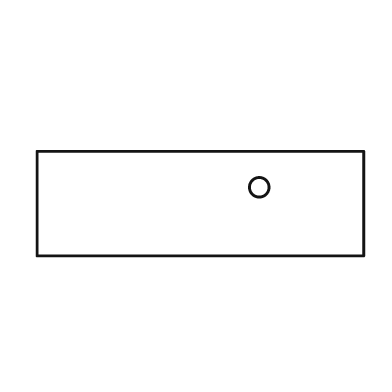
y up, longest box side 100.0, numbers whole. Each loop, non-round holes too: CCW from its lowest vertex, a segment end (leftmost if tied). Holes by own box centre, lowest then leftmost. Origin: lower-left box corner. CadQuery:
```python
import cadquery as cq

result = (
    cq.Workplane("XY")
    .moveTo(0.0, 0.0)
    .lineTo(100.0, 0.0)
    .lineTo(100.0, 32.0)
    .lineTo(0.0, 32.0)
    .close()
    .moveTo(68.0, 21.0)
    .circle(3.0)
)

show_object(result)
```